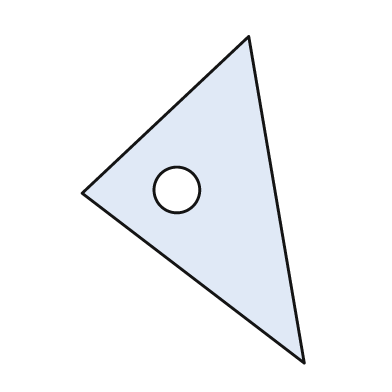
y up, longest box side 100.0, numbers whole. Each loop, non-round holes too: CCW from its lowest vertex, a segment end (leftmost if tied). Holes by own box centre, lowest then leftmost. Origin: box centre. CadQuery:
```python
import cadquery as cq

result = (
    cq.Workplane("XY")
    .moveTo(34.0, -50.0)
    .lineTo(17.0, 50.0)
    .lineTo(-34.0, 2.0)
    .close()
    .moveTo(-5.0, 3.0)
    .circle(7.0)
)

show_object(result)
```